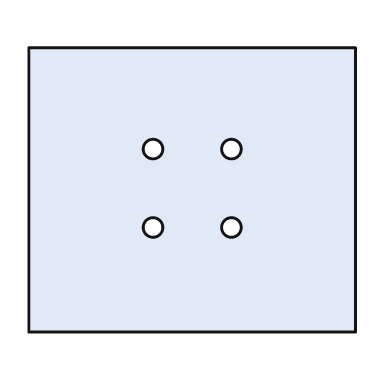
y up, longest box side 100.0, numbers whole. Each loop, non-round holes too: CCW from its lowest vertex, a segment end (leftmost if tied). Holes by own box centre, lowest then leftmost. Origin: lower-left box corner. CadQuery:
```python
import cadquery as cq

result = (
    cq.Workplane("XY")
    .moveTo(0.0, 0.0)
    .lineTo(100.0, 0.0)
    .lineTo(100.0, 87.0)
    .lineTo(0.0, 87.0)
    .close()
    .moveTo(38.0, 32.0)
    .circle(3.0)
    .moveTo(62.0, 32.0)
    .circle(3.0)
    .moveTo(38.0, 56.0)
    .circle(3.0)
    .moveTo(62.0, 56.0)
    .circle(3.0)
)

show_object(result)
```